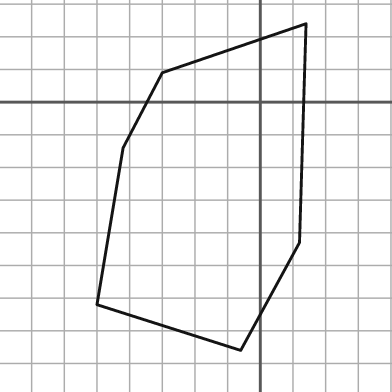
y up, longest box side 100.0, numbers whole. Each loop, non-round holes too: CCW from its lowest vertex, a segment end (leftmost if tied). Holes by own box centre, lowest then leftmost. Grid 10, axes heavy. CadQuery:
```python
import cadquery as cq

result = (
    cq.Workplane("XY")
    .moveTo(-6.0, -76.0)
    .lineTo(12.0, -43.0)
    .lineTo(14.0, 24.0)
    .lineTo(-30.0, 9.0)
    .lineTo(-42.0, -14.0)
    .lineTo(-50.0, -62.0)
    .close()
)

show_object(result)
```